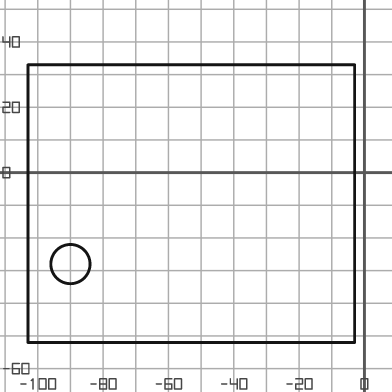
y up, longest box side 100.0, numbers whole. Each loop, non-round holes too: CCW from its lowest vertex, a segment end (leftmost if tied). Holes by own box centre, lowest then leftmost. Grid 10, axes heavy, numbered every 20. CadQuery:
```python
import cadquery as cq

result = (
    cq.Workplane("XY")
    .moveTo(-103.0, -52.0)
    .lineTo(-3.0, -52.0)
    .lineTo(-3.0, 33.0)
    .lineTo(-103.0, 33.0)
    .close()
    .moveTo(-90.0, -28.0)
    .circle(6.0)
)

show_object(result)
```